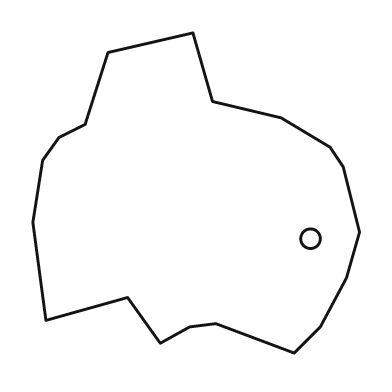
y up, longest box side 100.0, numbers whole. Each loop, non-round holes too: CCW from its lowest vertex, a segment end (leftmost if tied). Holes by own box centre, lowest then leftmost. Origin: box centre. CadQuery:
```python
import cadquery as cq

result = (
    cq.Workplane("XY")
    .moveTo(30.0, -49.0)
    .lineTo(38.0, -41.0)
    .lineTo(46.0, -26.0)
    .lineTo(50.0, -12.0)
    .lineTo(45.0, 8.0)
    .lineTo(41.0, 14.0)
    .lineTo(26.0, 23.0)
    .lineTo(5.0, 28.0)
    .lineTo(-1.0, 49.0)
    .lineTo(-27.0, 43.0)
    .lineTo(-34.0, 21.0)
    .lineTo(-42.0, 17.0)
    .lineTo(-47.0, 10.0)
    .lineTo(-50.0, -9.0)
    .lineTo(-46.0, -39.0)
    .lineTo(-21.0, -32.0)
    .lineTo(-11.0, -46.0)
    .lineTo(-2.0, -41.0)
    .lineTo(6.0, -40.0)
    .close()
    .moveTo(35.0, -14.0)
    .circle(3.0)
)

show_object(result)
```